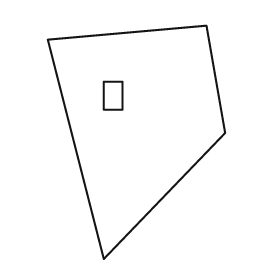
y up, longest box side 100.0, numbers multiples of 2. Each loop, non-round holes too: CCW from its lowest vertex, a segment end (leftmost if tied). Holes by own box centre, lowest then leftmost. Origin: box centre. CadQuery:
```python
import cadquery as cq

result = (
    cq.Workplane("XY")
    .moveTo(-14.0, -50.0)
    .lineTo(38.0, 4.0)
    .lineTo(30.0, 50.0)
    .lineTo(-38.0, 44.0)
    .close()
    .moveTo(-14.0, 14.0)
    .lineTo(-6.0, 14.0)
    .lineTo(-6.0, 26.0)
    .lineTo(-14.0, 26.0)
    .close()
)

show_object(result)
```